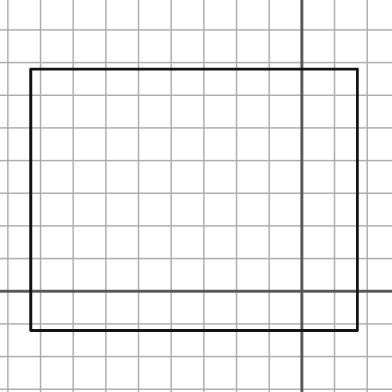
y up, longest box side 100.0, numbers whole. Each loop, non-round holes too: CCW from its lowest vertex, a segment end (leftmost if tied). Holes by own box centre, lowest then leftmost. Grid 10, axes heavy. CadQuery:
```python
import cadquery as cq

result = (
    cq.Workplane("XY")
    .moveTo(-83.0, -12.0)
    .lineTo(17.0, -12.0)
    .lineTo(17.0, 68.0)
    .lineTo(-83.0, 68.0)
    .close()
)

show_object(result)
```